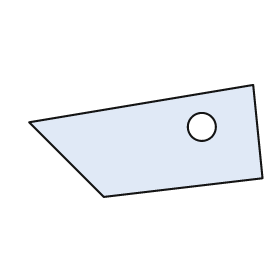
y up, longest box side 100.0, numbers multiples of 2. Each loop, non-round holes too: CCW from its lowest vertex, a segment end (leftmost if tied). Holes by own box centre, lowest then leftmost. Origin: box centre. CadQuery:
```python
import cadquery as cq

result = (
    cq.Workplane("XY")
    .moveTo(-18.0, -24.0)
    .lineTo(50.0, -16.0)
    .lineTo(46.0, 24.0)
    .lineTo(-50.0, 8.0)
    .close()
    .moveTo(24.0, 6.0)
    .circle(6.0)
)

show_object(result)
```